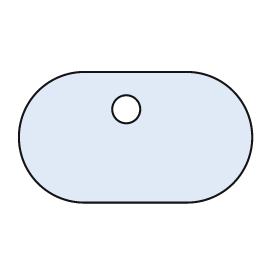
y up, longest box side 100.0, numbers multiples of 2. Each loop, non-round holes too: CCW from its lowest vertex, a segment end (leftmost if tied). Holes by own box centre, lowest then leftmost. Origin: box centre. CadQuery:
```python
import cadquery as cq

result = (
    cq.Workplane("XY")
    .moveTo(-22.0, -28.0)
    .lineTo(22.0, -28.0)
    .threePointArc((50.0, 0.0), (22.0, 28.0))
    .lineTo(-22.0, 28.0)
    .threePointArc((-50.0, 0.0), (-22.0, -28.0))
    .close()
    .moveTo(-4.0, 12.0)
    .circle(6.0)
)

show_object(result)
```